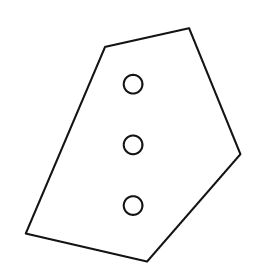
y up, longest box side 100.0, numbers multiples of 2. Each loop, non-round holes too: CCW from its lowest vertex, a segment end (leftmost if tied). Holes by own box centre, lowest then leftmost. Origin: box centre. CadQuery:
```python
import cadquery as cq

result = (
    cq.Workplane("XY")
    .moveTo(6.0, -50.0)
    .lineTo(46.0, -4.0)
    .lineTo(24.0, 50.0)
    .lineTo(-12.0, 42.0)
    .lineTo(-46.0, -38.0)
    .close()
    .moveTo(0.0, -26.0)
    .circle(4.0)
    .moveTo(0.0, 0.0)
    .circle(4.0)
    .moveTo(0.0, 26.0)
    .circle(4.0)
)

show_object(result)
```